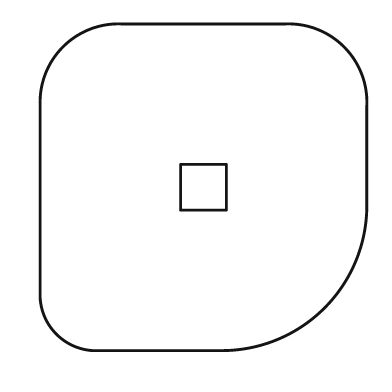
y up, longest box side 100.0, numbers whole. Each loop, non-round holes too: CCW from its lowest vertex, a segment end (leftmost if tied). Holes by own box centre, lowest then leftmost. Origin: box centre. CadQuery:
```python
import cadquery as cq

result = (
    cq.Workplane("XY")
    .moveTo(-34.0, -50.0)
    .lineTo(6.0, -50.0)
    .threePointArc((37.0, -37.0), (50.0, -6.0))
    .lineTo(50.0, 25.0)
    .threePointArc((43.0, 43.0), (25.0, 50.0))
    .lineTo(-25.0, 50.0)
    .threePointArc((-43.0, 43.0), (-50.0, 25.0))
    .lineTo(-50.0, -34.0)
    .threePointArc((-45.0, -45.0), (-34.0, -50.0))
    .close()
    .moveTo(-7.0, -7.0)
    .lineTo(7.0, -7.0)
    .lineTo(7.0, 7.0)
    .lineTo(-7.0, 7.0)
    .close()
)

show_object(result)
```